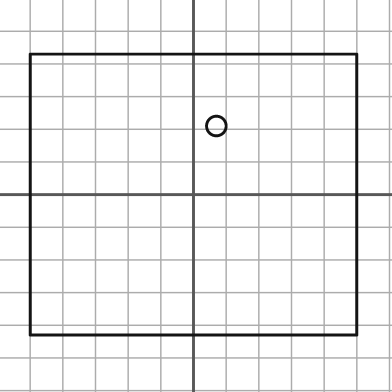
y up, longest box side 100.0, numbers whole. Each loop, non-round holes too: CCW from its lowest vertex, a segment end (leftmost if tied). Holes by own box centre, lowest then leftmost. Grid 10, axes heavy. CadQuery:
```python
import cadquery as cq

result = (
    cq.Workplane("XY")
    .moveTo(-50.0, -43.0)
    .lineTo(50.0, -43.0)
    .lineTo(50.0, 43.0)
    .lineTo(-50.0, 43.0)
    .close()
    .moveTo(7.0, 21.0)
    .circle(3.0)
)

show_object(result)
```